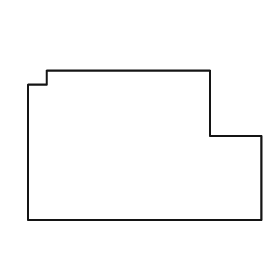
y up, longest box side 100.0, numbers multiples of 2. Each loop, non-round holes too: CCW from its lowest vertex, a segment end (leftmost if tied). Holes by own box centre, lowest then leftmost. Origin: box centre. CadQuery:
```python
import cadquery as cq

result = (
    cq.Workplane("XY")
    .moveTo(-50.0, -32.0)
    .lineTo(50.0, -32.0)
    .lineTo(50.0, 4.0)
    .lineTo(28.0, 4.0)
    .lineTo(28.0, 32.0)
    .lineTo(-42.0, 32.0)
    .lineTo(-42.0, 26.0)
    .lineTo(-50.0, 26.0)
    .close()
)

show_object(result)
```